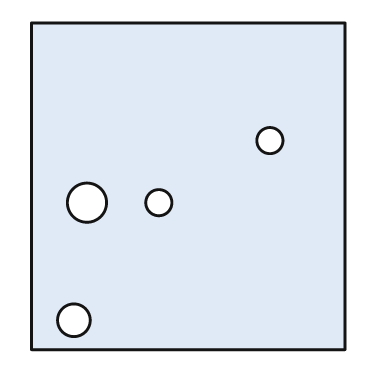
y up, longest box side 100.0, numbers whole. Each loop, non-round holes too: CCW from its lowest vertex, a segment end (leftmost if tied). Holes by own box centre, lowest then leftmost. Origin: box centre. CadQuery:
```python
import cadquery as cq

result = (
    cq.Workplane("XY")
    .moveTo(-48.0, -50.0)
    .lineTo(48.0, -50.0)
    .lineTo(48.0, 50.0)
    .lineTo(-48.0, 50.0)
    .close()
    .moveTo(-35.0, -41.0)
    .circle(5.0)
    .moveTo(-31.0, -5.0)
    .circle(6.0)
    .moveTo(-9.0, -5.0)
    .circle(4.0)
    .moveTo(25.0, 14.0)
    .circle(4.0)
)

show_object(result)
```